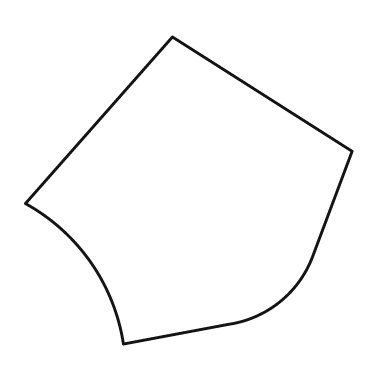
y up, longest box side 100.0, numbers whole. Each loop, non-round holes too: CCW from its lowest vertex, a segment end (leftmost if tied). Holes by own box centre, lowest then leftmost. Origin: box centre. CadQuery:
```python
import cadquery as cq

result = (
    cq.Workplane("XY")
    .moveTo(-20.0, -47.0)
    .lineTo(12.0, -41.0)
    .threePointArc((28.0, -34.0), (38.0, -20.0))
    .lineTo(50.0, 12.0)
    .lineTo(-5.0, 47.0)
    .lineTo(-50.0, -4.0)
    .threePointArc((-30.0, -22.0), (-20.0, -47.0))
    .close()
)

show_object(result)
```